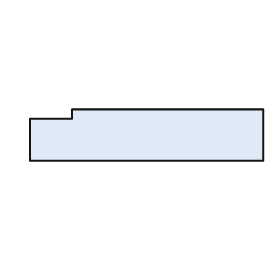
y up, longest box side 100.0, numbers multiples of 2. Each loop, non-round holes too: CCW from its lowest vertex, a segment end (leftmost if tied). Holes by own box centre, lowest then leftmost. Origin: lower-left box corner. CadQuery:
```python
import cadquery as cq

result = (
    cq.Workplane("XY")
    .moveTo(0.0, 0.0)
    .lineTo(100.0, 0.0)
    .lineTo(100.0, 22.0)
    .lineTo(18.0, 22.0)
    .lineTo(18.0, 18.0)
    .lineTo(0.0, 18.0)
    .close()
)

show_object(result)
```